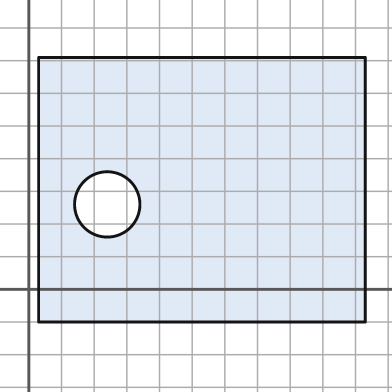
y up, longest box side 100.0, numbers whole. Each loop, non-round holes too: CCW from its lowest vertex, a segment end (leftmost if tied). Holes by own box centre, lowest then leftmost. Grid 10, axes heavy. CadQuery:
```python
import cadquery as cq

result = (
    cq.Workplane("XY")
    .moveTo(3.0, -10.0)
    .lineTo(103.0, -10.0)
    .lineTo(103.0, 71.0)
    .lineTo(3.0, 71.0)
    .close()
    .moveTo(24.0, 26.0)
    .circle(10.0)
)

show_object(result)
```